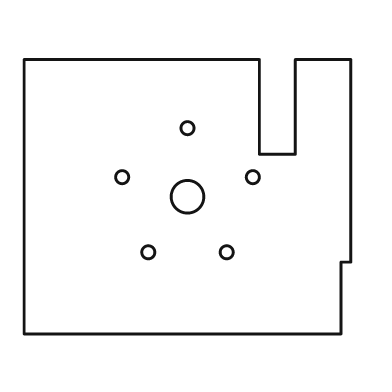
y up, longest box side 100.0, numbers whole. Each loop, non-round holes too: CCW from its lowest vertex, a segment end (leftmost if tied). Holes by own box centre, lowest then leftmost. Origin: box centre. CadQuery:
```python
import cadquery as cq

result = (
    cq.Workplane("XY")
    .moveTo(-50.0, -42.0)
    .lineTo(47.0, -42.0)
    .lineTo(47.0, -20.0)
    .lineTo(50.0, -20.0)
    .lineTo(50.0, 42.0)
    .lineTo(33.0, 42.0)
    .lineTo(33.0, 13.0)
    .lineTo(22.0, 13.0)
    .lineTo(22.0, 42.0)
    .lineTo(-50.0, 42.0)
    .close()
    .moveTo(-12.0, -17.0)
    .circle(2.0)
    .moveTo(12.0, -17.0)
    .circle(2.0)
    .moveTo(0.0, 0.0)
    .circle(5.0)
    .moveTo(-20.0, 6.0)
    .circle(2.0)
    .moveTo(20.0, 6.0)
    .circle(2.0)
    .moveTo(0.0, 21.0)
    .circle(2.0)
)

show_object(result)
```